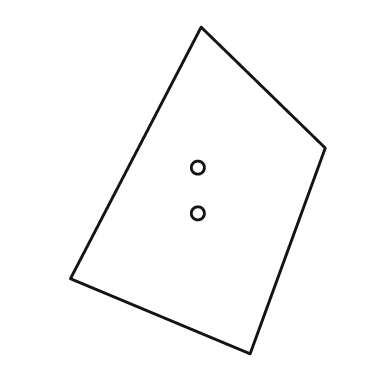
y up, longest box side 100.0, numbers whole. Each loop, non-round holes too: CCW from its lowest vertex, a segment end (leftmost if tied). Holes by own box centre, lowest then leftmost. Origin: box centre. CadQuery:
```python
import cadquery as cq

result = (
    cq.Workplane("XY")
    .moveTo(16.0, -50.0)
    .lineTo(39.0, 13.0)
    .lineTo(1.0, 50.0)
    .lineTo(-39.0, -27.0)
    .close()
    .moveTo(0.0, -7.0)
    .circle(2.0)
    .moveTo(0.0, 7.0)
    .circle(2.0)
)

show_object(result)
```